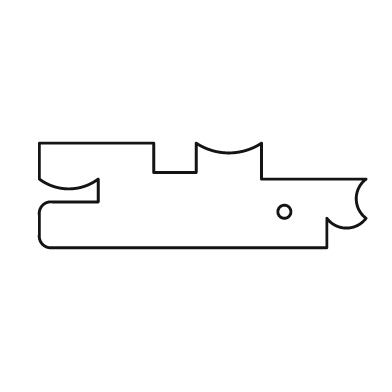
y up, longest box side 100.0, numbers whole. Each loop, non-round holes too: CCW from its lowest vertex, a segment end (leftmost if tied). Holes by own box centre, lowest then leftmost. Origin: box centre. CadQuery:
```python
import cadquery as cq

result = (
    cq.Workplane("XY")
    .moveTo(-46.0, -16.0)
    .lineTo(38.0, -16.0)
    .lineTo(38.0, -7.0)
    .threePointArc((44.0, -10.0), (50.0, -7.0))
    .threePointArc((47.0, -1.0), (50.0, 5.0))
    .lineTo(18.0, 5.0)
    .lineTo(18.0, 16.0)
    .threePointArc((8.0, 13.0), (-2.0, 16.0))
    .lineTo(-2.0, 7.0)
    .lineTo(-15.0, 7.0)
    .lineTo(-15.0, 16.0)
    .lineTo(-50.0, 16.0)
    .lineTo(-50.0, 5.0)
    .threePointArc((-41.0, 2.0), (-32.0, 5.0))
    .lineTo(-32.0, -2.0)
    .lineTo(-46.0, -2.0)
    .threePointArc((-49.0, -3.0), (-50.0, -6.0))
    .lineTo(-50.0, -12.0)
    .threePointArc((-49.0, -15.0), (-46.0, -16.0))
    .close()
    .moveTo(25.0, -5.0)
    .circle(2.0)
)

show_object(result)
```